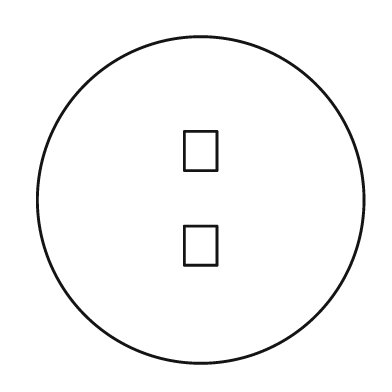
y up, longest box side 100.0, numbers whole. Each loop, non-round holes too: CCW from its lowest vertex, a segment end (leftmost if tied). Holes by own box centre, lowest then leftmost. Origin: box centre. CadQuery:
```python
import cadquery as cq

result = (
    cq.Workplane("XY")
    .moveTo(0.0, 0.0)
    .circle(50.0)
    .moveTo(-5.0, -20.0)
    .lineTo(5.0, -20.0)
    .lineTo(5.0, -8.0)
    .lineTo(-5.0, -8.0)
    .close()
    .moveTo(-5.0, 9.0)
    .lineTo(5.0, 9.0)
    .lineTo(5.0, 21.0)
    .lineTo(-5.0, 21.0)
    .close()
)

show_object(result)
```